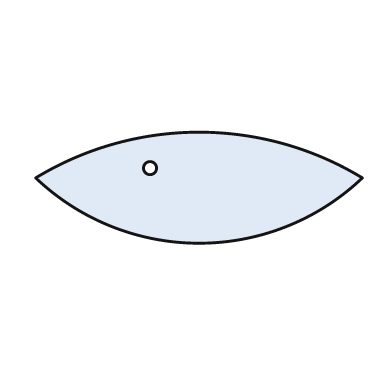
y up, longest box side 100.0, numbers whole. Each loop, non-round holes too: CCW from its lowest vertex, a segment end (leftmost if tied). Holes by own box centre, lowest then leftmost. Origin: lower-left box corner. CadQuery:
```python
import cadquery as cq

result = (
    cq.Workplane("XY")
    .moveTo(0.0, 20.0)
    .threePointArc((50.0, 0.0), (100.0, 20.0))
    .threePointArc((50.0, 34.0), (0.0, 20.0))
    .close()
    .moveTo(35.0, 23.0)
    .circle(2.0)
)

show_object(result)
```